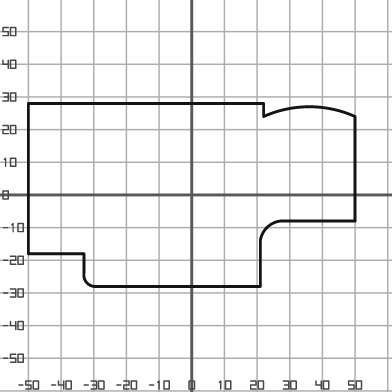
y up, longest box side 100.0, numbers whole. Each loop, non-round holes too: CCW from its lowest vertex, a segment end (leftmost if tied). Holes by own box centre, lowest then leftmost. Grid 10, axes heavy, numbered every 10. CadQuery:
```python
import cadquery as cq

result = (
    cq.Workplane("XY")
    .moveTo(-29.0, -28.0)
    .lineTo(21.0, -28.0)
    .lineTo(21.0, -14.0)
    .threePointArc((23.0, -10.0), (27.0, -8.0))
    .lineTo(50.0, -8.0)
    .lineTo(50.0, 24.0)
    .threePointArc((36.0, 27.0), (22.0, 24.0))
    .lineTo(22.0, 28.0)
    .lineTo(-50.0, 28.0)
    .lineTo(-50.0, -18.0)
    .lineTo(-33.0, -18.0)
    .lineTo(-33.0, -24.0)
    .threePointArc((-32.0, -27.0), (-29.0, -28.0))
    .close()
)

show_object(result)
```